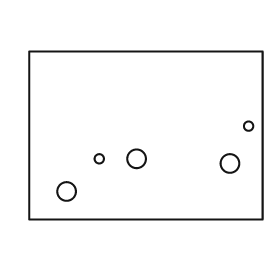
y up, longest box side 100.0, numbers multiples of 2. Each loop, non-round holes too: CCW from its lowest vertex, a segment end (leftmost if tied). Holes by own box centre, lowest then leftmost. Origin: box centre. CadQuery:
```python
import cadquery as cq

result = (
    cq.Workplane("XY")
    .moveTo(-50.0, -36.0)
    .lineTo(50.0, -36.0)
    .lineTo(50.0, 36.0)
    .lineTo(-50.0, 36.0)
    .close()
    .moveTo(-34.0, -24.0)
    .circle(4.0)
    .moveTo(36.0, -12.0)
    .circle(4.0)
    .moveTo(-20.0, -10.0)
    .circle(2.0)
    .moveTo(-4.0, -10.0)
    .circle(4.0)
    .moveTo(44.0, 4.0)
    .circle(2.0)
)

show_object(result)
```